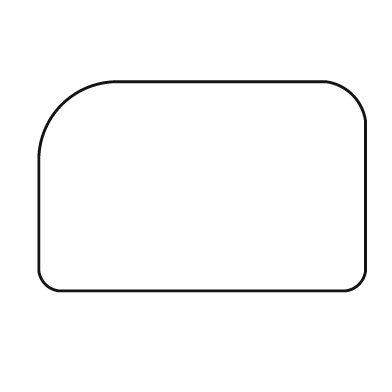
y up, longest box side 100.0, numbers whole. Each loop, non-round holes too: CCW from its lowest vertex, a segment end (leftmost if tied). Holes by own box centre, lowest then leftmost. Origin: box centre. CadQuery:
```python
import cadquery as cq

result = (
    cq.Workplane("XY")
    .moveTo(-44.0, -32.0)
    .lineTo(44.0, -32.0)
    .threePointArc((48.0, -30.0), (50.0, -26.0))
    .lineTo(50.0, 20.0)
    .threePointArc((46.0, 28.0), (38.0, 32.0))
    .lineTo(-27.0, 32.0)
    .threePointArc((-43.0, 25.0), (-50.0, 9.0))
    .lineTo(-50.0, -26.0)
    .threePointArc((-48.0, -30.0), (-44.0, -32.0))
    .close()
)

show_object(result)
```